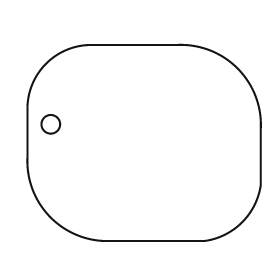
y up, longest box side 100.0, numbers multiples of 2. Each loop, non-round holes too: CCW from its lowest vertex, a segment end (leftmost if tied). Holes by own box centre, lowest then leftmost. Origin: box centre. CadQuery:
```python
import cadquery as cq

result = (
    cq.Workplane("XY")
    .moveTo(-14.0, -42.0)
    .lineTo(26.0, -42.0)
    .threePointArc((42.0, -34.0), (50.0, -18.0))
    .lineTo(50.0, 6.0)
    .threePointArc((40.0, 32.0), (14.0, 42.0))
    .lineTo(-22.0, 42.0)
    .threePointArc((-42.0, 34.0), (-50.0, 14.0))
    .lineTo(-50.0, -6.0)
    .threePointArc((-40.0, -32.0), (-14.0, -42.0))
    .close()
    .moveTo(-40.0, 8.0)
    .circle(4.0)
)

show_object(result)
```